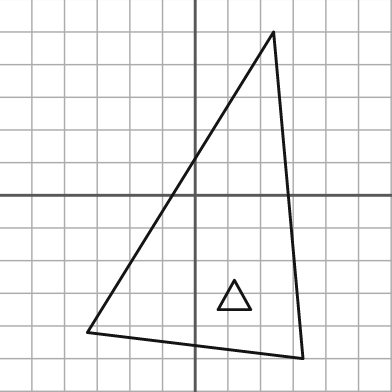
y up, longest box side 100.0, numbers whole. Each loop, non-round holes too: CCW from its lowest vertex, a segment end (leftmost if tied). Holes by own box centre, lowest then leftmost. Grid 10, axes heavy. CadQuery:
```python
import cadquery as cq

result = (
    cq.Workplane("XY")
    .moveTo(33.0, -50.0)
    .lineTo(24.0, 50.0)
    .lineTo(-33.0, -42.0)
    .close()
    .moveTo(7.0, -35.0)
    .lineTo(17.0, -35.0)
    .lineTo(12.0, -26.0)
    .close()
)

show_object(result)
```